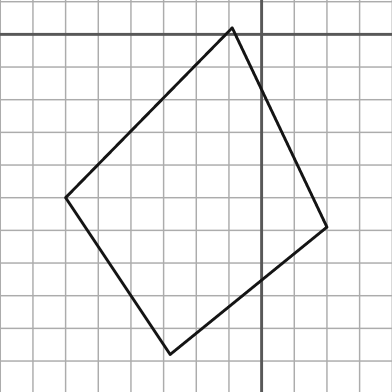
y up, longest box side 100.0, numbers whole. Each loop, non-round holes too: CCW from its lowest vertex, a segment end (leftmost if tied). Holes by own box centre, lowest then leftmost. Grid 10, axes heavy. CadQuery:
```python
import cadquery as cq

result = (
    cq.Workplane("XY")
    .moveTo(-28.0, -98.0)
    .lineTo(20.0, -59.0)
    .lineTo(-9.0, 2.0)
    .lineTo(-60.0, -50.0)
    .close()
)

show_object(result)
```